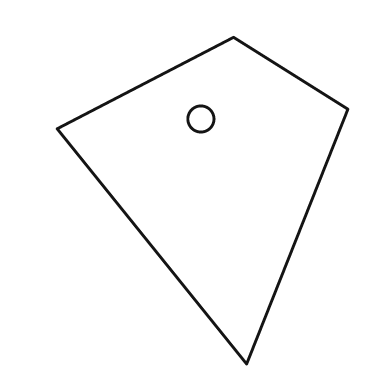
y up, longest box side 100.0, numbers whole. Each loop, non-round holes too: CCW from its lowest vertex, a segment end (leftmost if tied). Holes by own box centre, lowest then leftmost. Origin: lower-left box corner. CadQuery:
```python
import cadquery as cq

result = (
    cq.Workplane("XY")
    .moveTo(58.0, 0.0)
    .lineTo(89.0, 78.0)
    .lineTo(54.0, 100.0)
    .lineTo(0.0, 72.0)
    .close()
    .moveTo(44.0, 75.0)
    .circle(4.0)
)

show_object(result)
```